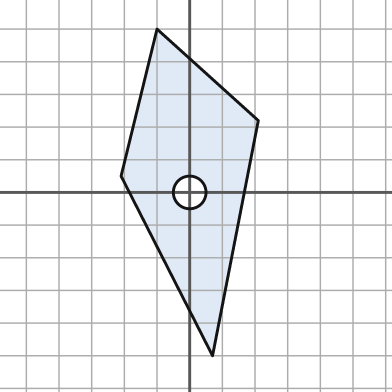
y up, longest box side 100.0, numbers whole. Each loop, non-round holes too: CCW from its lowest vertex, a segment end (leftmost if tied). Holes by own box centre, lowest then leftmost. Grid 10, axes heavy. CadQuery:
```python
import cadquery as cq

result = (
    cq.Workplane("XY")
    .moveTo(7.0, -50.0)
    .lineTo(21.0, 22.0)
    .lineTo(-10.0, 50.0)
    .lineTo(-21.0, 5.0)
    .close()
    .moveTo(0.0, 0.0)
    .circle(5.0)
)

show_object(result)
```